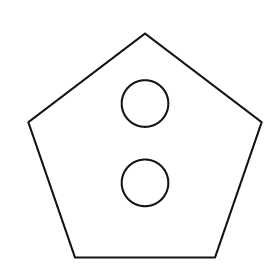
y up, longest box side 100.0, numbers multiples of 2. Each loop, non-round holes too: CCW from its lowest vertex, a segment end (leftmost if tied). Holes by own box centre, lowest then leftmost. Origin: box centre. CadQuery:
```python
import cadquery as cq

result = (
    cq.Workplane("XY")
    .moveTo(-30.0, -48.0)
    .lineTo(30.0, -48.0)
    .lineTo(50.0, 10.0)
    .lineTo(0.0, 48.0)
    .lineTo(-50.0, 10.0)
    .close()
    .moveTo(0.0, -16.0)
    .circle(10.0)
    .moveTo(0.0, 18.0)
    .circle(10.0)
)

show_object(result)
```